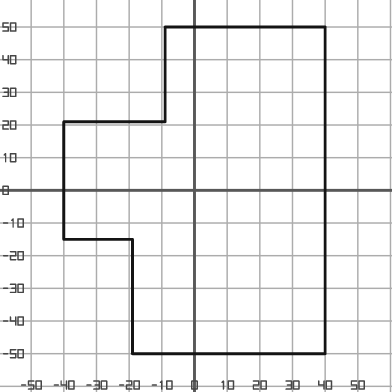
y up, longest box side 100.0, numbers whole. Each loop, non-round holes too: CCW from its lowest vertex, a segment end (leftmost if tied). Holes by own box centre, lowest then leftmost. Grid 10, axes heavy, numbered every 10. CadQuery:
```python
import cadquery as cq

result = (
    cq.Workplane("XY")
    .moveTo(-19.0, -50.0)
    .lineTo(40.0, -50.0)
    .lineTo(40.0, 50.0)
    .lineTo(-9.0, 50.0)
    .lineTo(-9.0, 21.0)
    .lineTo(-40.0, 21.0)
    .lineTo(-40.0, -15.0)
    .lineTo(-19.0, -15.0)
    .close()
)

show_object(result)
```